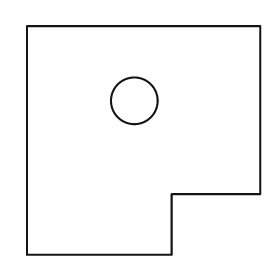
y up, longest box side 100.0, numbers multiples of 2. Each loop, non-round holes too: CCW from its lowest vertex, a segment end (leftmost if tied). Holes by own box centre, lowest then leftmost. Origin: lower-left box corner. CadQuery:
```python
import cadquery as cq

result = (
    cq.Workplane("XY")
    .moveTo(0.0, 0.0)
    .lineTo(62.0, 0.0)
    .lineTo(62.0, 26.0)
    .lineTo(100.0, 26.0)
    .lineTo(100.0, 98.0)
    .lineTo(0.0, 98.0)
    .close()
    .moveTo(46.0, 66.0)
    .circle(10.0)
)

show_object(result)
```